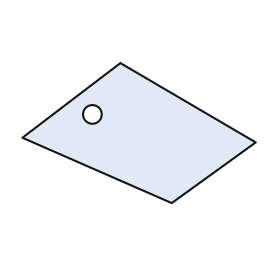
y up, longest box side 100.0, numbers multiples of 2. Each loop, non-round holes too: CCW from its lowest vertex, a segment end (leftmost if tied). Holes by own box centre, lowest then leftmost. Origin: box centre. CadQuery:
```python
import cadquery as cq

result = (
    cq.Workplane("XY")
    .moveTo(14.0, -30.0)
    .lineTo(50.0, -4.0)
    .lineTo(-8.0, 30.0)
    .lineTo(-50.0, -2.0)
    .close()
    .moveTo(-20.0, 8.0)
    .circle(4.0)
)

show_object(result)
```